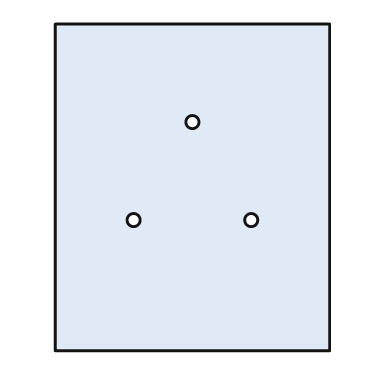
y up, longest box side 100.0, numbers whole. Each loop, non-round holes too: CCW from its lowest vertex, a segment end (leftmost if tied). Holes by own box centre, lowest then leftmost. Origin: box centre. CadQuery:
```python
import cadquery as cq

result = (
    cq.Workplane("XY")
    .moveTo(-42.0, -50.0)
    .lineTo(42.0, -50.0)
    .lineTo(42.0, 50.0)
    .lineTo(-42.0, 50.0)
    .close()
    .moveTo(-18.0, -10.0)
    .circle(2.0)
    .moveTo(18.0, -10.0)
    .circle(2.0)
    .moveTo(0.0, 20.0)
    .circle(2.0)
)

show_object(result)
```